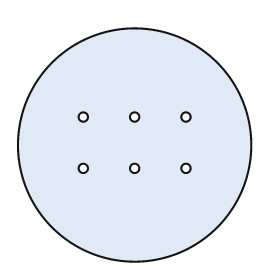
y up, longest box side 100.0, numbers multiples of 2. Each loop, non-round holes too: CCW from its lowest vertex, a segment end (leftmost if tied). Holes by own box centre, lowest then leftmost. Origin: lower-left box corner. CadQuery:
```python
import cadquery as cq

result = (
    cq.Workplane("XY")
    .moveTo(50.0, 50.0)
    .circle(50.0)
    .moveTo(28.0, 40.0)
    .circle(2.0)
    .moveTo(50.0, 40.0)
    .circle(2.0)
    .moveTo(72.0, 40.0)
    .circle(2.0)
    .moveTo(28.0, 62.0)
    .circle(2.0)
    .moveTo(50.0, 62.0)
    .circle(2.0)
    .moveTo(72.0, 62.0)
    .circle(2.0)
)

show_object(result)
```